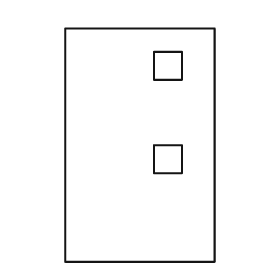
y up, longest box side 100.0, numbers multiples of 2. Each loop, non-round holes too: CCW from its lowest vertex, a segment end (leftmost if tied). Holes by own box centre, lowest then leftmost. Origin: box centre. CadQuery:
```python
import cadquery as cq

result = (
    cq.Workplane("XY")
    .moveTo(-32.0, -50.0)
    .lineTo(32.0, -50.0)
    .lineTo(32.0, 50.0)
    .lineTo(-32.0, 50.0)
    .close()
    .moveTo(6.0, -12.0)
    .lineTo(18.0, -12.0)
    .lineTo(18.0, 0.0)
    .lineTo(6.0, 0.0)
    .close()
    .moveTo(6.0, 28.0)
    .lineTo(18.0, 28.0)
    .lineTo(18.0, 40.0)
    .lineTo(6.0, 40.0)
    .close()
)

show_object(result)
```